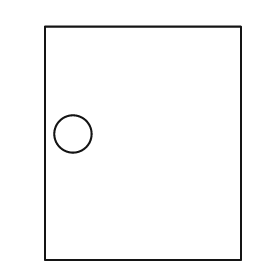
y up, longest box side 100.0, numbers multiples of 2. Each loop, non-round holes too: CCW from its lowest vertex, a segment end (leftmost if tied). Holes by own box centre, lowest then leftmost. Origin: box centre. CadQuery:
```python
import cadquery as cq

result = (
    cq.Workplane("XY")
    .moveTo(-42.0, -50.0)
    .lineTo(42.0, -50.0)
    .lineTo(42.0, 50.0)
    .lineTo(-42.0, 50.0)
    .close()
    .moveTo(-30.0, 4.0)
    .circle(8.0)
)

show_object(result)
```